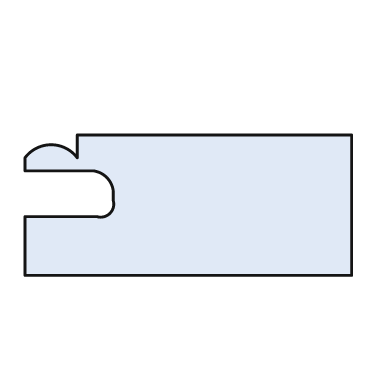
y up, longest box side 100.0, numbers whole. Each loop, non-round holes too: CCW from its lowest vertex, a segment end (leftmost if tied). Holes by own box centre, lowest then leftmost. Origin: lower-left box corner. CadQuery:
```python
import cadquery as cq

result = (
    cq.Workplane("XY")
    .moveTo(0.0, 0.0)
    .lineTo(100.0, 0.0)
    .lineTo(100.0, 43.0)
    .lineTo(16.0, 43.0)
    .lineTo(16.0, 36.0)
    .threePointArc((8.0, 40.0), (0.0, 36.0))
    .lineTo(0.0, 32.0)
    .lineTo(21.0, 32.0)
    .threePointArc((25.0, 30.0), (27.0, 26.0))
    .lineTo(27.0, 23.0)
    .threePointArc((26.0, 19.0), (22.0, 18.0))
    .lineTo(0.0, 18.0)
    .close()
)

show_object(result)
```